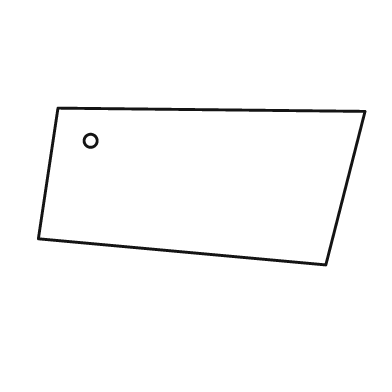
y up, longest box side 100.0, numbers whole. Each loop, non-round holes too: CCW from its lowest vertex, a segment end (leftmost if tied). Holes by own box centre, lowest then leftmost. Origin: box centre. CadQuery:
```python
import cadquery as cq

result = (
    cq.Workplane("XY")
    .moveTo(38.0, -24.0)
    .lineTo(50.0, 23.0)
    .lineTo(-44.0, 24.0)
    .lineTo(-50.0, -16.0)
    .close()
    .moveTo(-34.0, 14.0)
    .circle(2.0)
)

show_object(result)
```